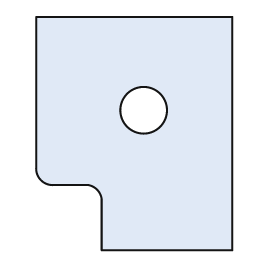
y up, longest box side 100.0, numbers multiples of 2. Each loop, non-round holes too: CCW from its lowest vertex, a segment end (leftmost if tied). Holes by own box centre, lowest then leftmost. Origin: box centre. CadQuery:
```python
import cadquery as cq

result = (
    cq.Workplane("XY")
    .moveTo(-14.0, -50.0)
    .lineTo(42.0, -50.0)
    .lineTo(42.0, 50.0)
    .lineTo(-42.0, 50.0)
    .lineTo(-42.0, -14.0)
    .threePointArc((-40.0, -20.0), (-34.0, -22.0))
    .lineTo(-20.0, -22.0)
    .threePointArc((-16.0, -24.0), (-14.0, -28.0))
    .close()
    .moveTo(4.0, 10.0)
    .circle(10.0)
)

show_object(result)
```